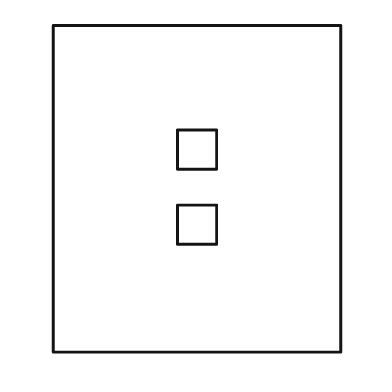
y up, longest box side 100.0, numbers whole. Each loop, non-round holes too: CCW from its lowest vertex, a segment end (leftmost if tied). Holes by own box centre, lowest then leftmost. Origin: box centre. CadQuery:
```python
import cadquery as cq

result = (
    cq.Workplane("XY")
    .moveTo(-44.0, -50.0)
    .lineTo(44.0, -50.0)
    .lineTo(44.0, 50.0)
    .lineTo(-44.0, 50.0)
    .close()
    .moveTo(-6.0, -17.0)
    .lineTo(6.0, -17.0)
    .lineTo(6.0, -5.0)
    .lineTo(-6.0, -5.0)
    .close()
    .moveTo(-6.0, 6.0)
    .lineTo(6.0, 6.0)
    .lineTo(6.0, 18.0)
    .lineTo(-6.0, 18.0)
    .close()
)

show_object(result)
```